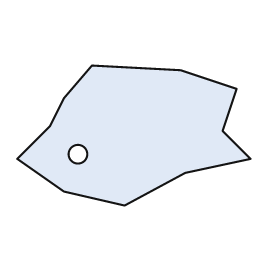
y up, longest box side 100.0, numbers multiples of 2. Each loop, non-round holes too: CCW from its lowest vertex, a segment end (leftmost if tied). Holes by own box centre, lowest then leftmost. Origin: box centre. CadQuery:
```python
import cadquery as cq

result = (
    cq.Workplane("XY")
    .moveTo(-4.0, -30.0)
    .lineTo(22.0, -16.0)
    .lineTo(50.0, -10.0)
    .lineTo(38.0, 2.0)
    .lineTo(44.0, 20.0)
    .lineTo(20.0, 28.0)
    .lineTo(-18.0, 30.0)
    .lineTo(-30.0, 16.0)
    .lineTo(-36.0, 4.0)
    .lineTo(-50.0, -10.0)
    .lineTo(-30.0, -24.0)
    .close()
    .moveTo(-24.0, -8.0)
    .circle(4.0)
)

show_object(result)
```